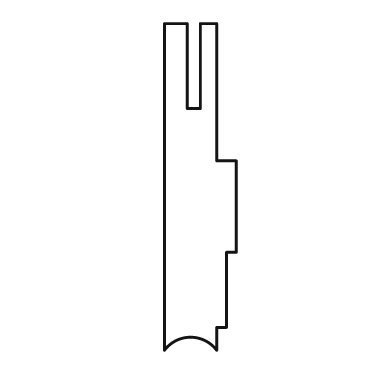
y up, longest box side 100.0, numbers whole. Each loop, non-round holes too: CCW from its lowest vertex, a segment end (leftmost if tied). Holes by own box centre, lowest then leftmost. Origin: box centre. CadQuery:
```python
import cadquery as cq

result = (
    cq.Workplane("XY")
    .moveTo(-11.0, -50.0)
    .threePointArc((-3.0, -46.0), (5.0, -50.0))
    .lineTo(5.0, -43.0)
    .lineTo(8.0, -43.0)
    .lineTo(8.0, -20.0)
    .lineTo(11.0, -20.0)
    .lineTo(11.0, 8.0)
    .lineTo(5.0, 8.0)
    .lineTo(5.0, 50.0)
    .lineTo(0.0, 50.0)
    .lineTo(0.0, 24.0)
    .lineTo(-4.0, 24.0)
    .lineTo(-4.0, 50.0)
    .lineTo(-11.0, 50.0)
    .close()
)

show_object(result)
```